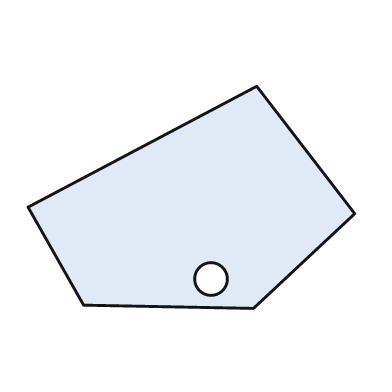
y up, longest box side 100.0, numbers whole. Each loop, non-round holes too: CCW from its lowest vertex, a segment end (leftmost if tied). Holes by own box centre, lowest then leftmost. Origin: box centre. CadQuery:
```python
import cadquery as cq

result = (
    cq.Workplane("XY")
    .moveTo(19.0, -34.0)
    .lineTo(50.0, -5.0)
    .lineTo(20.0, 34.0)
    .lineTo(-50.0, -3.0)
    .lineTo(-33.0, -33.0)
    .close()
    .moveTo(6.0, -25.0)
    .circle(5.0)
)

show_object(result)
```